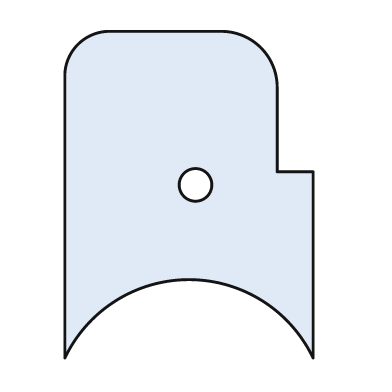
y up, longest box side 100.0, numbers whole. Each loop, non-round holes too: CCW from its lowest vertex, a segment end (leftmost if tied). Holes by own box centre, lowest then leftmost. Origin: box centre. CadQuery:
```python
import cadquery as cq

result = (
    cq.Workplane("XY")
    .moveTo(-38.0, -50.0)
    .threePointArc((0.0, -26.0), (38.0, -50.0))
    .lineTo(38.0, 7.0)
    .lineTo(27.0, 7.0)
    .lineTo(27.0, 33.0)
    .threePointArc((22.0, 45.0), (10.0, 50.0))
    .lineTo(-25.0, 50.0)
    .threePointArc((-34.0, 46.0), (-38.0, 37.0))
    .close()
    .moveTo(2.0, 3.0)
    .circle(5.0)
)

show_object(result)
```